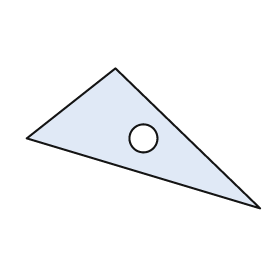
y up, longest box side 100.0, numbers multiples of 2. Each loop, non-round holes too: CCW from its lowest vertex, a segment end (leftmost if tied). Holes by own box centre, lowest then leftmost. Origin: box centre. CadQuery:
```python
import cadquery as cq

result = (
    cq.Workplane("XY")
    .moveTo(50.0, -30.0)
    .lineTo(-12.0, 30.0)
    .lineTo(-50.0, 0.0)
    .close()
    .moveTo(0.0, 0.0)
    .circle(6.0)
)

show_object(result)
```